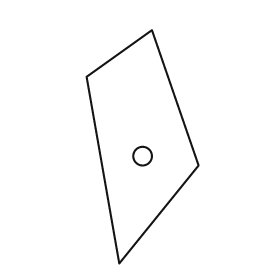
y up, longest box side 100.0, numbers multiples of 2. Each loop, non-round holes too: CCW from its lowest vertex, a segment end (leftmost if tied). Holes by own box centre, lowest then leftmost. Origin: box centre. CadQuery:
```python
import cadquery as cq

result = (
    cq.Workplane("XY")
    .moveTo(-10.0, -50.0)
    .lineTo(24.0, -8.0)
    .lineTo(4.0, 50.0)
    .lineTo(-24.0, 30.0)
    .close()
    .moveTo(0.0, -4.0)
    .circle(4.0)
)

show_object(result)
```